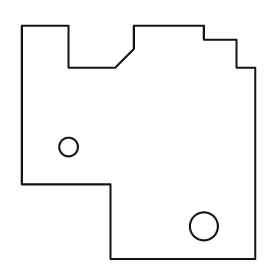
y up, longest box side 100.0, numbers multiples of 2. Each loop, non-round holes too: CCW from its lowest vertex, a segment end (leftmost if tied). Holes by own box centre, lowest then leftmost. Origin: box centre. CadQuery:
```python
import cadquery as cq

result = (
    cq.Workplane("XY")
    .moveTo(-12.0, -50.0)
    .lineTo(50.0, -50.0)
    .lineTo(50.0, 32.0)
    .lineTo(42.0, 32.0)
    .lineTo(42.0, 44.0)
    .lineTo(28.0, 44.0)
    .lineTo(28.0, 50.0)
    .lineTo(-2.0, 50.0)
    .lineTo(-2.0, 40.0)
    .lineTo(-10.0, 32.0)
    .lineTo(-30.0, 32.0)
    .lineTo(-30.0, 50.0)
    .lineTo(-50.0, 50.0)
    .lineTo(-50.0, -18.0)
    .lineTo(-12.0, -18.0)
    .close()
    .moveTo(28.0, -36.0)
    .circle(6.0)
    .moveTo(-30.0, -2.0)
    .circle(4.0)
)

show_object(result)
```